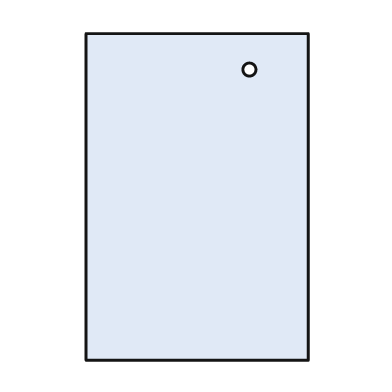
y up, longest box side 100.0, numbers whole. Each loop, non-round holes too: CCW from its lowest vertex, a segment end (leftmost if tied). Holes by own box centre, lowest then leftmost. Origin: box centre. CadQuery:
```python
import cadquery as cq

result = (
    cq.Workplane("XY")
    .moveTo(-34.0, -50.0)
    .lineTo(34.0, -50.0)
    .lineTo(34.0, 50.0)
    .lineTo(-34.0, 50.0)
    .close()
    .moveTo(16.0, 39.0)
    .circle(2.0)
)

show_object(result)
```